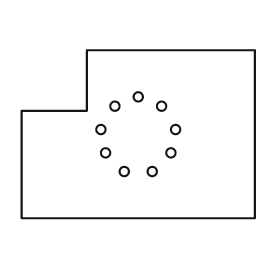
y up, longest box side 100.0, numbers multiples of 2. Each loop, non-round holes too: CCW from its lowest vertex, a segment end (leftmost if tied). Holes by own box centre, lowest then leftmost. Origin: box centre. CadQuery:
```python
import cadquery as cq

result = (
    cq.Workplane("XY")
    .moveTo(-50.0, -36.0)
    .lineTo(50.0, -36.0)
    .lineTo(50.0, 36.0)
    .lineTo(-22.0, 36.0)
    .lineTo(-22.0, 10.0)
    .lineTo(-50.0, 10.0)
    .close()
    .moveTo(-6.0, -16.0)
    .circle(2.0)
    .moveTo(6.0, -16.0)
    .circle(2.0)
    .moveTo(-14.0, -8.0)
    .circle(2.0)
    .moveTo(14.0, -8.0)
    .circle(2.0)
    .moveTo(-16.0, 2.0)
    .circle(2.0)
    .moveTo(16.0, 2.0)
    .circle(2.0)
    .moveTo(-10.0, 12.0)
    .circle(2.0)
    .moveTo(10.0, 12.0)
    .circle(2.0)
    .moveTo(0.0, 16.0)
    .circle(2.0)
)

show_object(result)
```